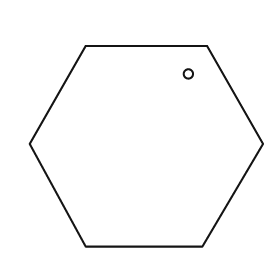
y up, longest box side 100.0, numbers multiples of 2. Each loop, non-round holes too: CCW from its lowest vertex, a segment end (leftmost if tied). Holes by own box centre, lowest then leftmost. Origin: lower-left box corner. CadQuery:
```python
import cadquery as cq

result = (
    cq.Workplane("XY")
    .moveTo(24.0, 0.0)
    .lineTo(74.0, 0.0)
    .lineTo(100.0, 44.0)
    .lineTo(76.0, 86.0)
    .lineTo(24.0, 86.0)
    .lineTo(0.0, 44.0)
    .close()
    .moveTo(68.0, 74.0)
    .circle(2.0)
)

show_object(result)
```